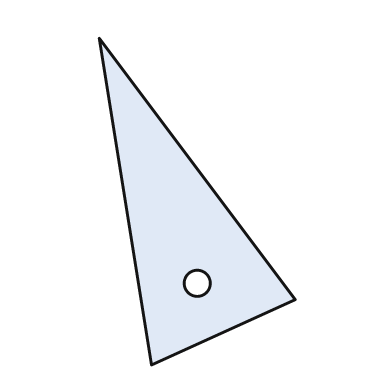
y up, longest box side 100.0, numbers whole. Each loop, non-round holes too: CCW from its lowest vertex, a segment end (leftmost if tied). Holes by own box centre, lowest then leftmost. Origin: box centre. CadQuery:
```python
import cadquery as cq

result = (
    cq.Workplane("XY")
    .moveTo(-14.0, -50.0)
    .lineTo(30.0, -30.0)
    .lineTo(-30.0, 50.0)
    .close()
    .moveTo(0.0, -25.0)
    .circle(4.0)
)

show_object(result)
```